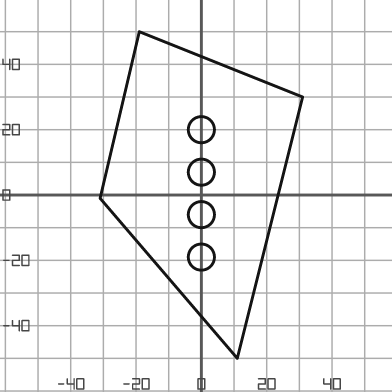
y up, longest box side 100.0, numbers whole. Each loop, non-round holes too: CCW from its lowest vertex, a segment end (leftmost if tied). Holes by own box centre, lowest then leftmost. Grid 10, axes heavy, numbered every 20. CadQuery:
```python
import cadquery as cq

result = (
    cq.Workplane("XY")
    .moveTo(11.0, -50.0)
    .lineTo(31.0, 30.0)
    .lineTo(-19.0, 50.0)
    .lineTo(-31.0, -1.0)
    .close()
    .moveTo(0.0, -19.0)
    .circle(4.0)
    .moveTo(0.0, -6.0)
    .circle(4.0)
    .moveTo(0.0, 7.0)
    .circle(4.0)
    .moveTo(0.0, 20.0)
    .circle(4.0)
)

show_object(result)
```